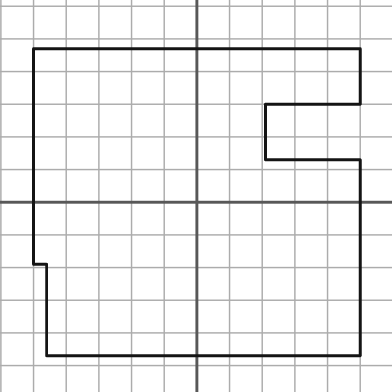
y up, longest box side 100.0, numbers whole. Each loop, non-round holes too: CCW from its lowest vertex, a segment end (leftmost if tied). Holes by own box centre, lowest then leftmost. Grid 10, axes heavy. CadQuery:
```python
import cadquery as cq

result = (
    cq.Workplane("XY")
    .moveTo(-46.0, -47.0)
    .lineTo(50.0, -47.0)
    .lineTo(50.0, 13.0)
    .lineTo(21.0, 13.0)
    .lineTo(21.0, 30.0)
    .lineTo(50.0, 30.0)
    .lineTo(50.0, 47.0)
    .lineTo(-50.0, 47.0)
    .lineTo(-50.0, -19.0)
    .lineTo(-46.0, -19.0)
    .close()
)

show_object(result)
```